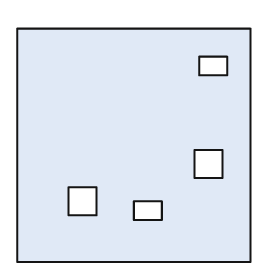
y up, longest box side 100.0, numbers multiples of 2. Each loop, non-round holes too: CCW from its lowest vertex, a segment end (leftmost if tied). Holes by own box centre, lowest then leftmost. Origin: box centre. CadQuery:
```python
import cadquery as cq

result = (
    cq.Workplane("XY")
    .moveTo(-50.0, -50.0)
    .lineTo(50.0, -50.0)
    .lineTo(50.0, 50.0)
    .lineTo(-50.0, 50.0)
    .close()
    .moveTo(0.0, -32.0)
    .lineTo(12.0, -32.0)
    .lineTo(12.0, -24.0)
    .lineTo(0.0, -24.0)
    .close()
    .moveTo(-28.0, -30.0)
    .lineTo(-16.0, -30.0)
    .lineTo(-16.0, -18.0)
    .lineTo(-28.0, -18.0)
    .close()
    .moveTo(26.0, -14.0)
    .lineTo(38.0, -14.0)
    .lineTo(38.0, -2.0)
    .lineTo(26.0, -2.0)
    .close()
    .moveTo(28.0, 30.0)
    .lineTo(40.0, 30.0)
    .lineTo(40.0, 38.0)
    .lineTo(28.0, 38.0)
    .close()
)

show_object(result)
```